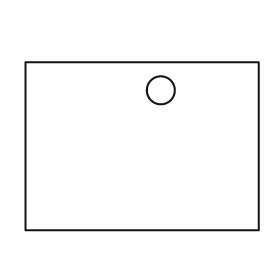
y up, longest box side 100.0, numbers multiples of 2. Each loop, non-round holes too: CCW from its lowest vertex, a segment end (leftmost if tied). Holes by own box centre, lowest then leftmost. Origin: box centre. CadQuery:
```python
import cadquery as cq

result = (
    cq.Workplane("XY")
    .moveTo(-50.0, -36.0)
    .lineTo(50.0, -36.0)
    .lineTo(50.0, 36.0)
    .lineTo(-50.0, 36.0)
    .close()
    .moveTo(8.0, 24.0)
    .circle(6.0)
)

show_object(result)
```